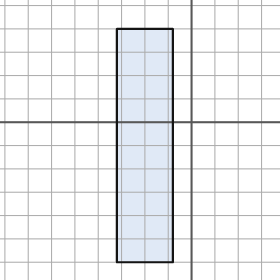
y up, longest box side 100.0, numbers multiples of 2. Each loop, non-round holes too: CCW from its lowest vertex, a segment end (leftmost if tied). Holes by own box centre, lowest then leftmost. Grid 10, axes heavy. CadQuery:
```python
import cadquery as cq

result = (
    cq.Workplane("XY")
    .moveTo(-32.0, -60.0)
    .lineTo(-8.0, -60.0)
    .lineTo(-8.0, 40.0)
    .lineTo(-32.0, 40.0)
    .close()
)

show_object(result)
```